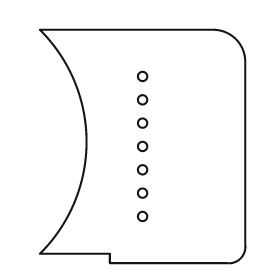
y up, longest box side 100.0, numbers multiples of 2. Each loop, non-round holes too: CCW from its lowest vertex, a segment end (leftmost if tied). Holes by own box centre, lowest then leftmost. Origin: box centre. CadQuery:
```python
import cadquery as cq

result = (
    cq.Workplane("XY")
    .moveTo(-14.0, -50.0)
    .lineTo(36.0, -50.0)
    .threePointArc((42.0, -48.0), (44.0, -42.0))
    .lineTo(44.0, 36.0)
    .threePointArc((40.0, 46.0), (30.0, 50.0))
    .lineTo(-44.0, 50.0)
    .threePointArc((-24.0, 2.0), (-44.0, -46.0))
    .lineTo(-14.0, -46.0)
    .close()
    .moveTo(0.0, -30.0)
    .circle(2.0)
    .moveTo(0.0, -20.0)
    .circle(2.0)
    .moveTo(0.0, -10.0)
    .circle(2.0)
    .moveTo(0.0, 0.0)
    .circle(2.0)
    .moveTo(0.0, 10.0)
    .circle(2.0)
    .moveTo(0.0, 20.0)
    .circle(2.0)
    .moveTo(0.0, 30.0)
    .circle(2.0)
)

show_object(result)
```